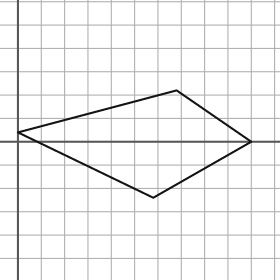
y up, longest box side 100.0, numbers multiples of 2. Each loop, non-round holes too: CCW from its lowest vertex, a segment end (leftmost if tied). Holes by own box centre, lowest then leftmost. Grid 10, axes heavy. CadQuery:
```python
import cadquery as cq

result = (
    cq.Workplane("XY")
    .moveTo(58.0, -24.0)
    .lineTo(100.0, 0.0)
    .lineTo(68.0, 22.0)
    .lineTo(0.0, 4.0)
    .close()
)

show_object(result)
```